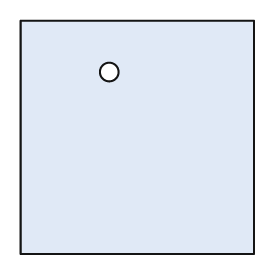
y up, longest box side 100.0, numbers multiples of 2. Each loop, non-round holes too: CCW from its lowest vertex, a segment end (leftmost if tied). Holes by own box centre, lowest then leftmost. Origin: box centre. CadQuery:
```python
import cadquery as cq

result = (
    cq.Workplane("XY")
    .moveTo(-50.0, -50.0)
    .lineTo(50.0, -50.0)
    .lineTo(50.0, 50.0)
    .lineTo(-50.0, 50.0)
    .close()
    .moveTo(-12.0, 28.0)
    .circle(4.0)
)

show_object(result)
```